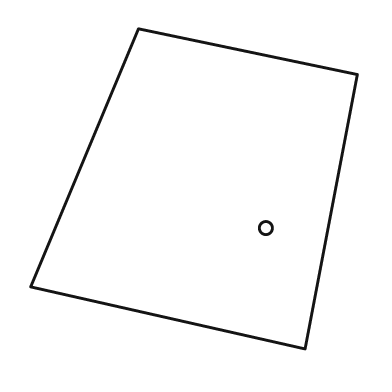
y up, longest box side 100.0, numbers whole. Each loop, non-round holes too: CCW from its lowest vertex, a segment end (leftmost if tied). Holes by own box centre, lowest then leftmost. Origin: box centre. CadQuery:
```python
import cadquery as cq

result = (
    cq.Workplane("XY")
    .moveTo(34.0, -49.0)
    .lineTo(50.0, 35.0)
    .lineTo(-17.0, 49.0)
    .lineTo(-50.0, -30.0)
    .close()
    .moveTo(22.0, -12.0)
    .circle(2.0)
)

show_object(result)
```